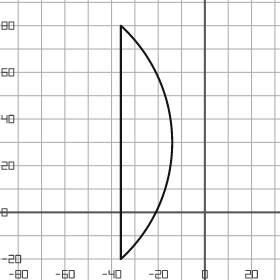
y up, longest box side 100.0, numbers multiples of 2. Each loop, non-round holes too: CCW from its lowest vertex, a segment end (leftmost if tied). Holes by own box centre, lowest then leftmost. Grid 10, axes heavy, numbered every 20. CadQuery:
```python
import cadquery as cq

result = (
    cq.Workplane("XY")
    .moveTo(-36.0, -20.0)
    .threePointArc((-14.0, 30.0), (-36.0, 80.0))
    .close()
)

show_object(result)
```